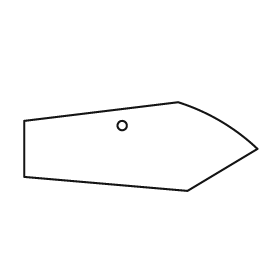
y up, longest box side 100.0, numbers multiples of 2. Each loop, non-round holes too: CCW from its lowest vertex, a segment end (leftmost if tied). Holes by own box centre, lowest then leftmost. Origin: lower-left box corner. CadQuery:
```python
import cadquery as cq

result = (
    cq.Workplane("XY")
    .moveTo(70.0, 0.0)
    .lineTo(100.0, 18.0)
    .threePointArc((84.0, 30.0), (66.0, 38.0))
    .lineTo(0.0, 30.0)
    .lineTo(0.0, 6.0)
    .close()
    .moveTo(42.0, 28.0)
    .circle(2.0)
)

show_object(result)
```